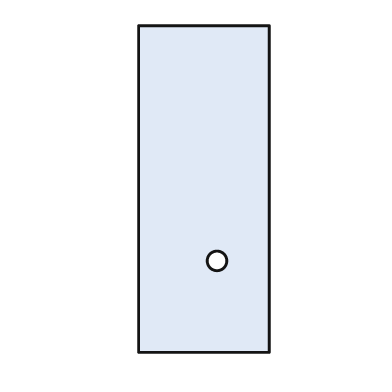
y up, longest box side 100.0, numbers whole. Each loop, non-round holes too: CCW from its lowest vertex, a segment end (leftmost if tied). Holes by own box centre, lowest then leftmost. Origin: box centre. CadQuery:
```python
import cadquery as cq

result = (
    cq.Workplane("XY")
    .moveTo(-20.0, -50.0)
    .lineTo(20.0, -50.0)
    .lineTo(20.0, 50.0)
    .lineTo(-20.0, 50.0)
    .close()
    .moveTo(4.0, -22.0)
    .circle(3.0)
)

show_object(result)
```